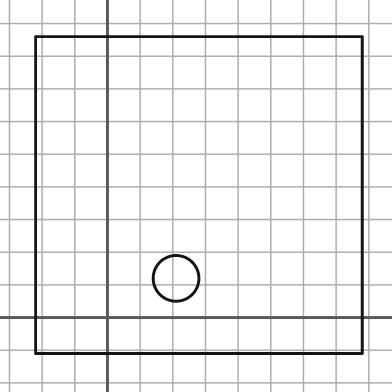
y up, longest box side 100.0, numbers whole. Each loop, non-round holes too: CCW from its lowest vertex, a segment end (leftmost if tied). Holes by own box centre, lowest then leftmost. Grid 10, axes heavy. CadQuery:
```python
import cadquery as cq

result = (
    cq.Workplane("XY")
    .moveTo(-22.0, -11.0)
    .lineTo(78.0, -11.0)
    .lineTo(78.0, 86.0)
    .lineTo(-22.0, 86.0)
    .close()
    .moveTo(21.0, 12.0)
    .circle(7.0)
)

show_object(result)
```